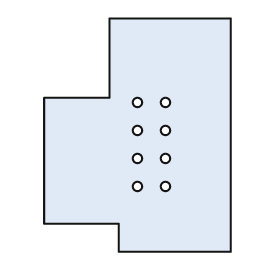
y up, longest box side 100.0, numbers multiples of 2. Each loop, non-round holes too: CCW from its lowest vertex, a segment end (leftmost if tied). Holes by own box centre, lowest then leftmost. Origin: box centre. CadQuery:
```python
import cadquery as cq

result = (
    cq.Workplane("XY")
    .moveTo(-8.0, -50.0)
    .lineTo(40.0, -50.0)
    .lineTo(40.0, 50.0)
    .lineTo(-12.0, 50.0)
    .lineTo(-12.0, 16.0)
    .lineTo(-40.0, 16.0)
    .lineTo(-40.0, -38.0)
    .lineTo(-8.0, -38.0)
    .close()
    .moveTo(0.0, -22.0)
    .circle(2.0)
    .moveTo(12.0, -22.0)
    .circle(2.0)
    .moveTo(0.0, -10.0)
    .circle(2.0)
    .moveTo(12.0, -10.0)
    .circle(2.0)
    .moveTo(0.0, 2.0)
    .circle(2.0)
    .moveTo(12.0, 2.0)
    .circle(2.0)
    .moveTo(0.0, 14.0)
    .circle(2.0)
    .moveTo(12.0, 14.0)
    .circle(2.0)
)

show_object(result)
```